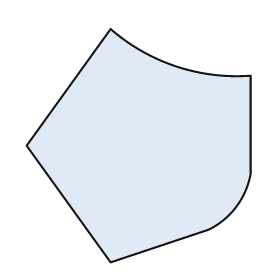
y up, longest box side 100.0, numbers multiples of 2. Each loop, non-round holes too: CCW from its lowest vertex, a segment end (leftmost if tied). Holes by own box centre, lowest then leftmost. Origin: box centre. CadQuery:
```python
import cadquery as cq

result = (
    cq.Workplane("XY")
    .moveTo(-12.0, -50.0)
    .lineTo(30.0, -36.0)
    .threePointArc((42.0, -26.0), (48.0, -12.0))
    .lineTo(48.0, 30.0)
    .threePointArc((16.0, 34.0), (-12.0, 50.0))
    .lineTo(-48.0, 0.0)
    .close()
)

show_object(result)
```